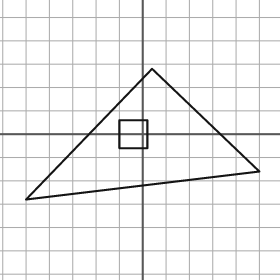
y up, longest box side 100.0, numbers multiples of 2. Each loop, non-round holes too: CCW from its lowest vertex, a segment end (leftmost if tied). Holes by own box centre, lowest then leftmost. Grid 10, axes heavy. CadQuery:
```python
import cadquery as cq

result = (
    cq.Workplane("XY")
    .moveTo(-50.0, -28.0)
    .lineTo(50.0, -16.0)
    .lineTo(4.0, 28.0)
    .close()
    .moveTo(-10.0, -6.0)
    .lineTo(2.0, -6.0)
    .lineTo(2.0, 6.0)
    .lineTo(-10.0, 6.0)
    .close()
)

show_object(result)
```